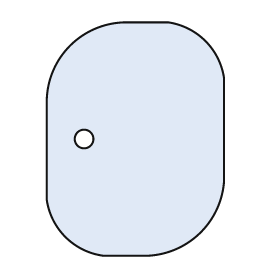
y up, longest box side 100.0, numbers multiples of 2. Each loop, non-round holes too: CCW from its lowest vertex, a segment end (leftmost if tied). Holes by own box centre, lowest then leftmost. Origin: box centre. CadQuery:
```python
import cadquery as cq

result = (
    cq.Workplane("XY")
    .moveTo(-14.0, -50.0)
    .lineTo(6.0, -50.0)
    .threePointArc((28.0, -40.0), (38.0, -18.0))
    .lineTo(38.0, 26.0)
    .threePointArc((30.0, 42.0), (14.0, 50.0))
    .lineTo(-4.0, 50.0)
    .threePointArc((-28.0, 40.0), (-38.0, 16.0))
    .lineTo(-38.0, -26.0)
    .threePointArc((-30.0, -42.0), (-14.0, -50.0))
    .close()
    .moveTo(-22.0, 0.0)
    .circle(4.0)
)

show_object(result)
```